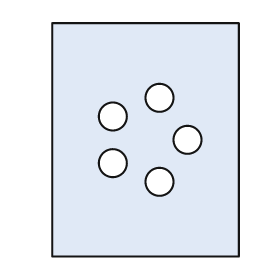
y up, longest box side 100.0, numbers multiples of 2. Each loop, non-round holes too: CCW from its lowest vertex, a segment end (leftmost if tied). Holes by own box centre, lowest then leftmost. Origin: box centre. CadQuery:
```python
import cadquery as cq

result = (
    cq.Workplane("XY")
    .moveTo(-40.0, -50.0)
    .lineTo(40.0, -50.0)
    .lineTo(40.0, 50.0)
    .lineTo(-40.0, 50.0)
    .close()
    .moveTo(6.0, -18.0)
    .circle(6.0)
    .moveTo(-14.0, -10.0)
    .circle(6.0)
    .moveTo(18.0, 0.0)
    .circle(6.0)
    .moveTo(-14.0, 10.0)
    .circle(6.0)
    .moveTo(6.0, 18.0)
    .circle(6.0)
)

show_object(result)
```